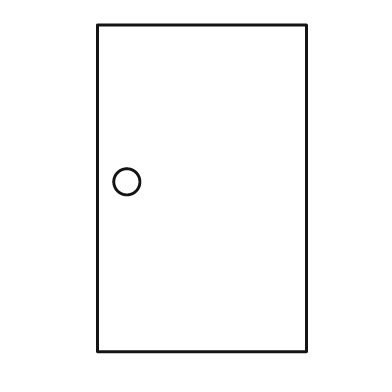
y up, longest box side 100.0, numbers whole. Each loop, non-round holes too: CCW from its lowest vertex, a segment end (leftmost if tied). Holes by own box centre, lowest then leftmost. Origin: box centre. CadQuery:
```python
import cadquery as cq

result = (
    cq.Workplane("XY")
    .moveTo(-32.0, -50.0)
    .lineTo(32.0, -50.0)
    .lineTo(32.0, 50.0)
    .lineTo(-32.0, 50.0)
    .close()
    .moveTo(-23.0, 2.0)
    .circle(4.0)
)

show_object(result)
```